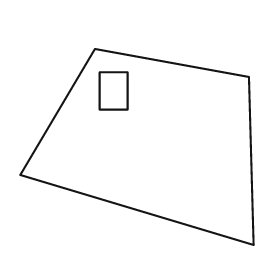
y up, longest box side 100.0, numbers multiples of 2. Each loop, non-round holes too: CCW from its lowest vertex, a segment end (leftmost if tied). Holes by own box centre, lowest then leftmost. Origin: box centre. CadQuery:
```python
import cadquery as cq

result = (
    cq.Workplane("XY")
    .moveTo(50.0, -42.0)
    .lineTo(48.0, 30.0)
    .lineTo(-18.0, 42.0)
    .lineTo(-50.0, -12.0)
    .close()
    .moveTo(-16.0, 16.0)
    .lineTo(-4.0, 16.0)
    .lineTo(-4.0, 32.0)
    .lineTo(-16.0, 32.0)
    .close()
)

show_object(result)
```